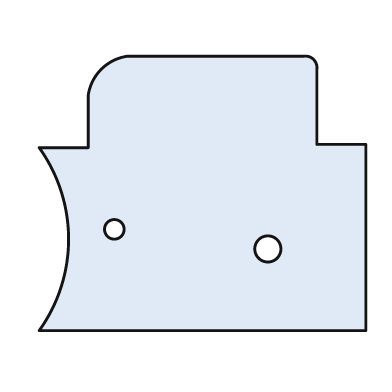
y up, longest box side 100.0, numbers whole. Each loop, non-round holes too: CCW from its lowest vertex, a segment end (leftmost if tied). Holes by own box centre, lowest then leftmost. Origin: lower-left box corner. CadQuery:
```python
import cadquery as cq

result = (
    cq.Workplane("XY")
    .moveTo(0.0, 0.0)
    .lineTo(100.0, 0.0)
    .lineTo(100.0, 57.0)
    .lineTo(85.0, 57.0)
    .lineTo(85.0, 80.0)
    .threePointArc((84.0, 83.0), (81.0, 84.0))
    .lineTo(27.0, 84.0)
    .threePointArc((19.0, 80.0), (15.0, 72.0))
    .lineTo(15.0, 56.0)
    .lineTo(0.0, 56.0)
    .threePointArc((9.0, 28.0), (0.0, 0.0))
    .close()
    .moveTo(70.0, 25.0)
    .circle(4.0)
    .moveTo(23.0, 31.0)
    .circle(3.0)
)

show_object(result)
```